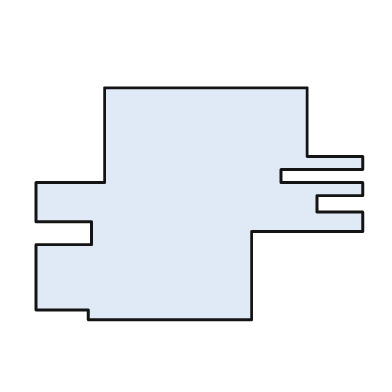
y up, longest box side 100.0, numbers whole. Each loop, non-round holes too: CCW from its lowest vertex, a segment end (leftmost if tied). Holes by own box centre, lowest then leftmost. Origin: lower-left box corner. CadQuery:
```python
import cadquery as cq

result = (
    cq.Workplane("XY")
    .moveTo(16.0, 0.0)
    .lineTo(66.0, 0.0)
    .lineTo(66.0, 27.0)
    .lineTo(100.0, 27.0)
    .lineTo(100.0, 33.0)
    .lineTo(86.0, 33.0)
    .lineTo(86.0, 38.0)
    .lineTo(100.0, 38.0)
    .lineTo(100.0, 42.0)
    .lineTo(75.0, 42.0)
    .lineTo(75.0, 46.0)
    .lineTo(100.0, 46.0)
    .lineTo(100.0, 50.0)
    .lineTo(83.0, 50.0)
    .lineTo(83.0, 71.0)
    .lineTo(21.0, 71.0)
    .lineTo(21.0, 42.0)
    .lineTo(0.0, 42.0)
    .lineTo(0.0, 30.0)
    .lineTo(17.0, 30.0)
    .lineTo(17.0, 23.0)
    .lineTo(0.0, 23.0)
    .lineTo(0.0, 3.0)
    .lineTo(16.0, 3.0)
    .close()
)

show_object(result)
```